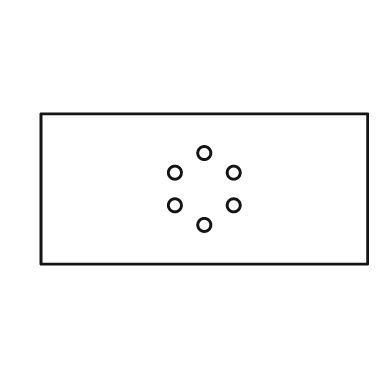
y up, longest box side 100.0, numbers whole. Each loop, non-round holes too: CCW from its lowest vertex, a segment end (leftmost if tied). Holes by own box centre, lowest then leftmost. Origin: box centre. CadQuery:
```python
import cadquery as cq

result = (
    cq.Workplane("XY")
    .moveTo(-50.0, -23.0)
    .lineTo(50.0, -23.0)
    .lineTo(50.0, 23.0)
    .lineTo(-50.0, 23.0)
    .close()
    .moveTo(0.0, -11.0)
    .circle(2.0)
    .moveTo(-9.0, -5.0)
    .circle(2.0)
    .moveTo(9.0, -5.0)
    .circle(2.0)
    .moveTo(-9.0, 5.0)
    .circle(2.0)
    .moveTo(9.0, 5.0)
    .circle(2.0)
    .moveTo(0.0, 11.0)
    .circle(2.0)
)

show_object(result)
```